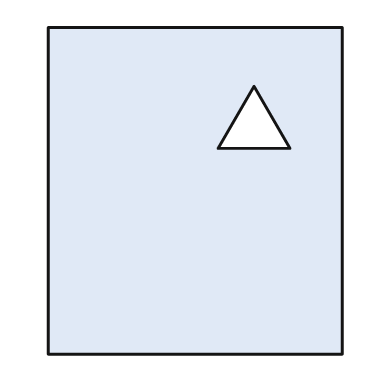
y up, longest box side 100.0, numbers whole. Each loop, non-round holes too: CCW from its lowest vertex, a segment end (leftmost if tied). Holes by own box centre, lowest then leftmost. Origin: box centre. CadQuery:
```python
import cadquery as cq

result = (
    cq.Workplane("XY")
    .moveTo(-45.0, -50.0)
    .lineTo(45.0, -50.0)
    .lineTo(45.0, 50.0)
    .lineTo(-45.0, 50.0)
    .close()
    .moveTo(7.0, 13.0)
    .lineTo(29.0, 13.0)
    .lineTo(18.0, 32.0)
    .close()
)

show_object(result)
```